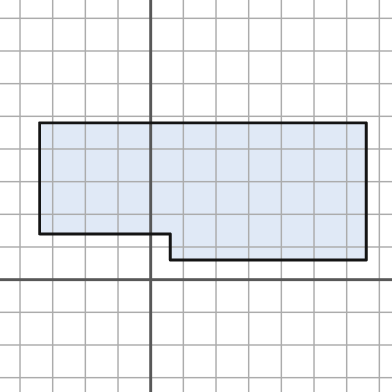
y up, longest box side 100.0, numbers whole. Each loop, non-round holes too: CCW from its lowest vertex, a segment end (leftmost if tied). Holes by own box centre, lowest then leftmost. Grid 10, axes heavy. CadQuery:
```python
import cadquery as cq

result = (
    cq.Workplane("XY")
    .moveTo(6.0, 6.0)
    .lineTo(66.0, 6.0)
    .lineTo(66.0, 48.0)
    .lineTo(-34.0, 48.0)
    .lineTo(-34.0, 14.0)
    .lineTo(6.0, 14.0)
    .close()
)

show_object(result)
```